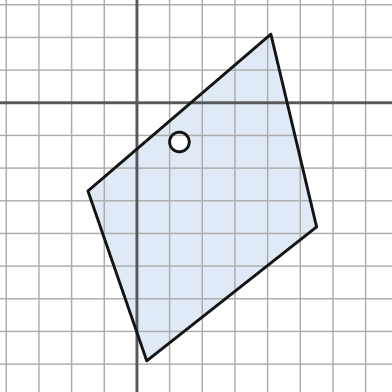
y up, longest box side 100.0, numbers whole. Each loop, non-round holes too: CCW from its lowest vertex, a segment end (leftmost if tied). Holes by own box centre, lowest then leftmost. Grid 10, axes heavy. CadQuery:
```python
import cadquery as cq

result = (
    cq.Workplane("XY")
    .moveTo(3.0, -79.0)
    .lineTo(55.0, -38.0)
    .lineTo(41.0, 21.0)
    .lineTo(-15.0, -27.0)
    .close()
    .moveTo(13.0, -12.0)
    .circle(3.0)
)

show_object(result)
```